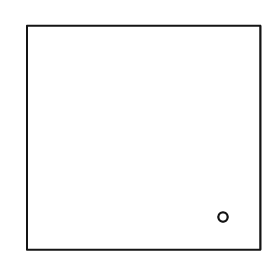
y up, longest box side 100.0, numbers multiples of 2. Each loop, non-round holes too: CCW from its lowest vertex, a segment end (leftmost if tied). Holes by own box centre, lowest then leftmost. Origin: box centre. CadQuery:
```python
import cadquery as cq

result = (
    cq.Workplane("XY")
    .moveTo(-50.0, -48.0)
    .lineTo(50.0, -48.0)
    .lineTo(50.0, 48.0)
    .lineTo(-50.0, 48.0)
    .close()
    .moveTo(34.0, -34.0)
    .circle(2.0)
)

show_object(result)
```